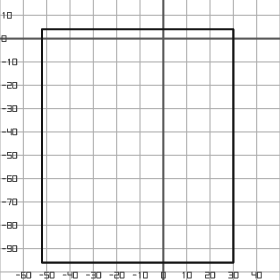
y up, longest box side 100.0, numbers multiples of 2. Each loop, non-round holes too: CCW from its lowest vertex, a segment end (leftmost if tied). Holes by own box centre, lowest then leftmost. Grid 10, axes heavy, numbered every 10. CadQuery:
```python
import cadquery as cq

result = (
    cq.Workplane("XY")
    .moveTo(-52.0, -96.0)
    .lineTo(30.0, -96.0)
    .lineTo(30.0, 4.0)
    .lineTo(-52.0, 4.0)
    .close()
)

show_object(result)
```